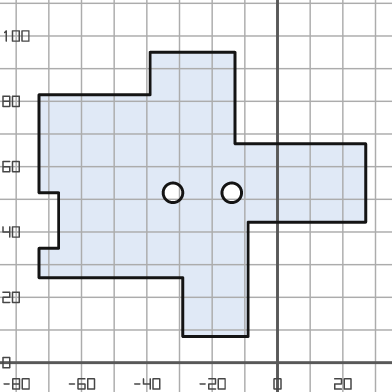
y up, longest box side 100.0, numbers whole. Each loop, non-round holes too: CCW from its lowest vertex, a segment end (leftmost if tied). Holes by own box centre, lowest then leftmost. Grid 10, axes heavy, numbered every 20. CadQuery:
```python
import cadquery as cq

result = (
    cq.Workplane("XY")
    .moveTo(-29.0, 8.0)
    .lineTo(-9.0, 8.0)
    .lineTo(-9.0, 43.0)
    .lineTo(27.0, 43.0)
    .lineTo(27.0, 67.0)
    .lineTo(-13.0, 67.0)
    .lineTo(-13.0, 95.0)
    .lineTo(-39.0, 95.0)
    .lineTo(-39.0, 82.0)
    .lineTo(-73.0, 82.0)
    .lineTo(-73.0, 52.0)
    .lineTo(-67.0, 52.0)
    .lineTo(-67.0, 35.0)
    .lineTo(-73.0, 35.0)
    .lineTo(-73.0, 26.0)
    .lineTo(-29.0, 26.0)
    .close()
    .moveTo(-32.0, 52.0)
    .circle(3.0)
    .moveTo(-14.0, 52.0)
    .circle(3.0)
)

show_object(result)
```